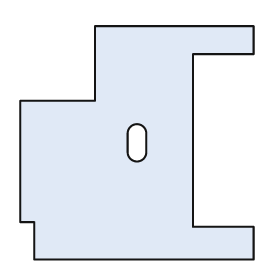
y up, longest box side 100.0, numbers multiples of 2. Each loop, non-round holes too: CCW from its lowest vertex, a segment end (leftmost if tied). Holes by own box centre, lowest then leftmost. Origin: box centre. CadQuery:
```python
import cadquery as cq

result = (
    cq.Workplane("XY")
    .moveTo(-44.0, -50.0)
    .lineTo(50.0, -50.0)
    .lineTo(50.0, -36.0)
    .lineTo(24.0, -36.0)
    .lineTo(24.0, 38.0)
    .lineTo(50.0, 38.0)
    .lineTo(50.0, 50.0)
    .lineTo(-18.0, 50.0)
    .lineTo(-18.0, 18.0)
    .lineTo(-50.0, 18.0)
    .lineTo(-50.0, -34.0)
    .lineTo(-44.0, -34.0)
    .close()
    .moveTo(-4.0, -4.0)
    .threePointArc((0.0, -8.0), (4.0, -4.0))
    .lineTo(4.0, 4.0)
    .threePointArc((0.0, 8.0), (-4.0, 4.0))
    .close()
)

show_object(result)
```